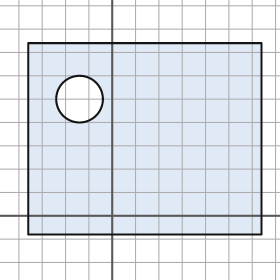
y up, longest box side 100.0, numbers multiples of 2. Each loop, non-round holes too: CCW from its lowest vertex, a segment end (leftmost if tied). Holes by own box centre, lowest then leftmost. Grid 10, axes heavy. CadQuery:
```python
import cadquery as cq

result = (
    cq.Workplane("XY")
    .moveTo(-36.0, -8.0)
    .lineTo(64.0, -8.0)
    .lineTo(64.0, 74.0)
    .lineTo(-36.0, 74.0)
    .close()
    .moveTo(-14.0, 50.0)
    .circle(10.0)
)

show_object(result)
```